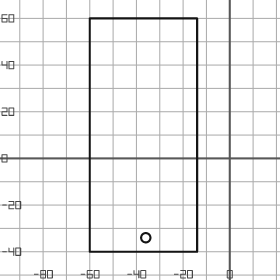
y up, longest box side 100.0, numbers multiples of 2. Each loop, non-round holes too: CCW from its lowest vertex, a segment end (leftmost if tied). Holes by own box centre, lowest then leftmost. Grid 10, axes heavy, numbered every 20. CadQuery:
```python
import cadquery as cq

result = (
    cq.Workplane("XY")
    .moveTo(-60.0, -40.0)
    .lineTo(-14.0, -40.0)
    .lineTo(-14.0, 60.0)
    .lineTo(-60.0, 60.0)
    .close()
    .moveTo(-36.0, -34.0)
    .circle(2.0)
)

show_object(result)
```